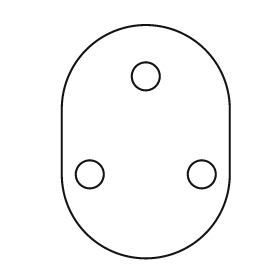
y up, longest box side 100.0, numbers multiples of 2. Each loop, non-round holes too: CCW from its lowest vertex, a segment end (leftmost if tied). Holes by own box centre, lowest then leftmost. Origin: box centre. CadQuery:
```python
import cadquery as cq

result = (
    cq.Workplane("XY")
    .moveTo(-36.0, -14.0)
    .threePointArc((0.0, -50.0), (36.0, -14.0))
    .lineTo(36.0, 14.0)
    .threePointArc((0.0, 50.0), (-36.0, 14.0))
    .close()
    .moveTo(-24.0, -14.0)
    .circle(6.0)
    .moveTo(24.0, -14.0)
    .circle(6.0)
    .moveTo(0.0, 28.0)
    .circle(6.0)
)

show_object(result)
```